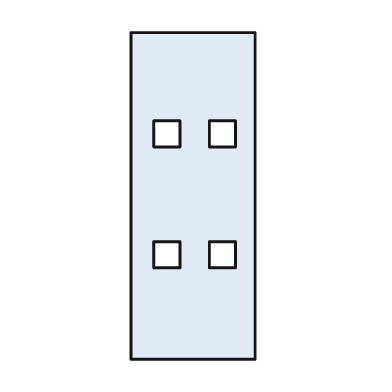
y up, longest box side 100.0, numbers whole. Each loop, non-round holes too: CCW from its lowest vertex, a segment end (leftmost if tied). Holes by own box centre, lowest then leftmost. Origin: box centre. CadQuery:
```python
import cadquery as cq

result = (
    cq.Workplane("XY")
    .moveTo(-19.0, -50.0)
    .lineTo(19.0, -50.0)
    .lineTo(19.0, 50.0)
    .lineTo(-19.0, 50.0)
    .close()
    .moveTo(-12.0, -22.0)
    .lineTo(-4.0, -22.0)
    .lineTo(-4.0, -14.0)
    .lineTo(-12.0, -14.0)
    .close()
    .moveTo(5.0, -22.0)
    .lineTo(13.0, -22.0)
    .lineTo(13.0, -14.0)
    .lineTo(5.0, -14.0)
    .close()
    .moveTo(-12.0, 15.0)
    .lineTo(-4.0, 15.0)
    .lineTo(-4.0, 23.0)
    .lineTo(-12.0, 23.0)
    .close()
    .moveTo(5.0, 15.0)
    .lineTo(13.0, 15.0)
    .lineTo(13.0, 23.0)
    .lineTo(5.0, 23.0)
    .close()
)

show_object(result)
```